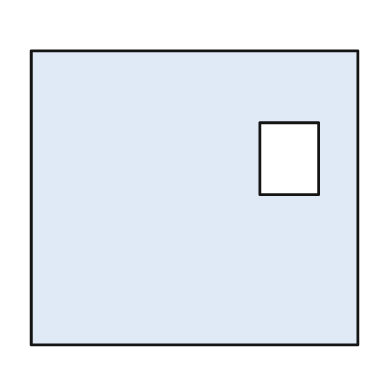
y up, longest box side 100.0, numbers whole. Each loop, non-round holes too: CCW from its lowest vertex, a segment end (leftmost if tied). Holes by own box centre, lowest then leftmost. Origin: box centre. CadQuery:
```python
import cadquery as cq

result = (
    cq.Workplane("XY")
    .moveTo(-50.0, -45.0)
    .lineTo(50.0, -45.0)
    .lineTo(50.0, 45.0)
    .lineTo(-50.0, 45.0)
    .close()
    .moveTo(20.0, 1.0)
    .lineTo(38.0, 1.0)
    .lineTo(38.0, 23.0)
    .lineTo(20.0, 23.0)
    .close()
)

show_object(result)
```